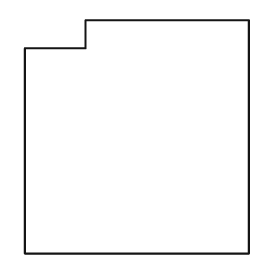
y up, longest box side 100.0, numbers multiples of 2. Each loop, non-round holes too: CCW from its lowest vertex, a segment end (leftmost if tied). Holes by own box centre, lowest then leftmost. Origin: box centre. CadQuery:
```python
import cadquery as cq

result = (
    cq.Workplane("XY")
    .moveTo(-48.0, -50.0)
    .lineTo(48.0, -50.0)
    .lineTo(48.0, 50.0)
    .lineTo(-22.0, 50.0)
    .lineTo(-22.0, 38.0)
    .lineTo(-48.0, 38.0)
    .close()
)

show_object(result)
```